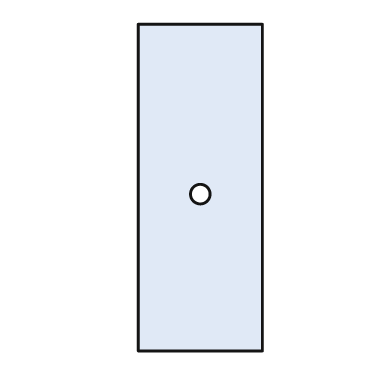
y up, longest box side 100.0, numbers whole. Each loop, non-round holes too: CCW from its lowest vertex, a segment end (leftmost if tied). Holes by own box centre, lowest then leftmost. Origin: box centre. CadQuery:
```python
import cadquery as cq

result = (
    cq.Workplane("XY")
    .moveTo(-19.0, -50.0)
    .lineTo(19.0, -50.0)
    .lineTo(19.0, 50.0)
    .lineTo(-19.0, 50.0)
    .close()
    .moveTo(0.0, -2.0)
    .circle(3.0)
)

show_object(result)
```